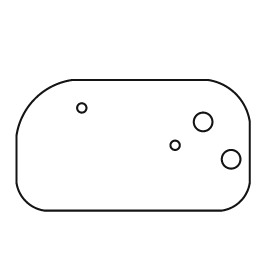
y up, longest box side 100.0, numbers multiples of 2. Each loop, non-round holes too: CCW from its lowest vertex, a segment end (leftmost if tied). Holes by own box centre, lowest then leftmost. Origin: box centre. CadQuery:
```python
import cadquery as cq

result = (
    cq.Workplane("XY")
    .moveTo(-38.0, -28.0)
    .lineTo(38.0, -28.0)
    .threePointArc((46.0, -24.0), (50.0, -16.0))
    .lineTo(50.0, 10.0)
    .threePointArc((44.0, 22.0), (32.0, 28.0))
    .lineTo(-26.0, 28.0)
    .threePointArc((-42.0, 20.0), (-50.0, 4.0))
    .lineTo(-50.0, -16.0)
    .threePointArc((-46.0, -24.0), (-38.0, -28.0))
    .close()
    .moveTo(42.0, -6.0)
    .circle(4.0)
    .moveTo(18.0, 0.0)
    .circle(2.0)
    .moveTo(30.0, 10.0)
    .circle(4.0)
    .moveTo(-22.0, 16.0)
    .circle(2.0)
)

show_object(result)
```